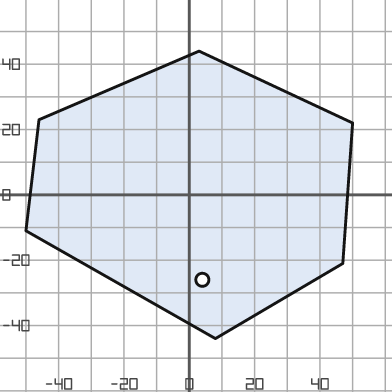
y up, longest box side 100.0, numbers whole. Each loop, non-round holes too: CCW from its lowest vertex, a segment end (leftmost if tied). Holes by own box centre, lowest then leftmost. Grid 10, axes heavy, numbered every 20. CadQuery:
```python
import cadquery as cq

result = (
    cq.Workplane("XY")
    .moveTo(8.0, -44.0)
    .lineTo(47.0, -21.0)
    .lineTo(50.0, 22.0)
    .lineTo(3.0, 44.0)
    .lineTo(-46.0, 23.0)
    .lineTo(-50.0, -11.0)
    .close()
    .moveTo(4.0, -26.0)
    .circle(2.0)
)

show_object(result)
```